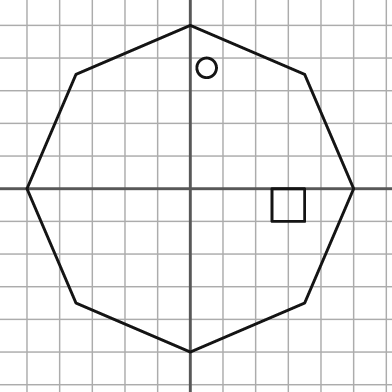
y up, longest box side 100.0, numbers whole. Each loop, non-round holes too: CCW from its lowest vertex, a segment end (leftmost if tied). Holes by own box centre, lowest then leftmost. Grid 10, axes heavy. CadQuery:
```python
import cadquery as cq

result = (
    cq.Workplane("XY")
    .moveTo(0.0, -50.0)
    .lineTo(35.0, -35.0)
    .lineTo(50.0, 0.0)
    .lineTo(35.0, 35.0)
    .lineTo(0.0, 50.0)
    .lineTo(-35.0, 35.0)
    .lineTo(-50.0, 0.0)
    .lineTo(-35.0, -35.0)
    .close()
    .moveTo(25.0, -10.0)
    .lineTo(35.0, -10.0)
    .lineTo(35.0, 0.0)
    .lineTo(25.0, 0.0)
    .close()
    .moveTo(5.0, 37.0)
    .circle(3.0)
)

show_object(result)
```